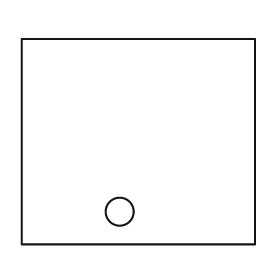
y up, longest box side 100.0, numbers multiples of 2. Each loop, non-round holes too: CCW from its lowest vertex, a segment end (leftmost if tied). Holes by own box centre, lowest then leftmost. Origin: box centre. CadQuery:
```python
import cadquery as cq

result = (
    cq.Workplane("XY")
    .moveTo(-50.0, -44.0)
    .lineTo(50.0, -44.0)
    .lineTo(50.0, 44.0)
    .lineTo(-50.0, 44.0)
    .close()
    .moveTo(-8.0, -30.0)
    .circle(6.0)
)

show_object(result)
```